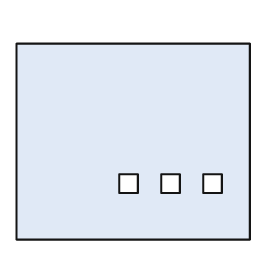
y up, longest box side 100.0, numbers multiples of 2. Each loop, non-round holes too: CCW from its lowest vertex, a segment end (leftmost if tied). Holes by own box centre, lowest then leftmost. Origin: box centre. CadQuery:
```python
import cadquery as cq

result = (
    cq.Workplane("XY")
    .moveTo(-50.0, -42.0)
    .lineTo(50.0, -42.0)
    .lineTo(50.0, 42.0)
    .lineTo(-50.0, 42.0)
    .close()
    .moveTo(-6.0, -22.0)
    .lineTo(2.0, -22.0)
    .lineTo(2.0, -14.0)
    .lineTo(-6.0, -14.0)
    .close()
    .moveTo(12.0, -22.0)
    .lineTo(20.0, -22.0)
    .lineTo(20.0, -14.0)
    .lineTo(12.0, -14.0)
    .close()
    .moveTo(30.0, -22.0)
    .lineTo(38.0, -22.0)
    .lineTo(38.0, -14.0)
    .lineTo(30.0, -14.0)
    .close()
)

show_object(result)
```